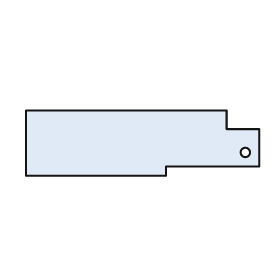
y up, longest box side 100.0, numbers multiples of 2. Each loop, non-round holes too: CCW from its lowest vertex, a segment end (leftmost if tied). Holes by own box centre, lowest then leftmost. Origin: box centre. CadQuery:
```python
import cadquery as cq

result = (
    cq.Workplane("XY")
    .moveTo(-50.0, -14.0)
    .lineTo(10.0, -14.0)
    .lineTo(10.0, -10.0)
    .lineTo(50.0, -10.0)
    .lineTo(50.0, 6.0)
    .lineTo(36.0, 6.0)
    .lineTo(36.0, 14.0)
    .lineTo(-50.0, 14.0)
    .close()
    .moveTo(44.0, -4.0)
    .circle(2.0)
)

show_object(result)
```